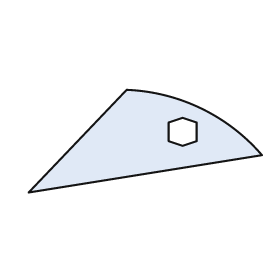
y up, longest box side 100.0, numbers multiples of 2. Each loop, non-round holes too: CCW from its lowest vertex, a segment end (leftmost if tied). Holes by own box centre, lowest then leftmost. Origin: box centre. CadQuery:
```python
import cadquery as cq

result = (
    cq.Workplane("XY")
    .moveTo(-50.0, -22.0)
    .lineTo(50.0, -6.0)
    .threePointArc((24.0, 14.0), (-8.0, 22.0))
    .close()
    .moveTo(16.0, -2.0)
    .lineTo(22.0, 0.0)
    .lineTo(22.0, 8.0)
    .lineTo(16.0, 10.0)
    .lineTo(10.0, 8.0)
    .lineTo(10.0, 0.0)
    .close()
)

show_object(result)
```